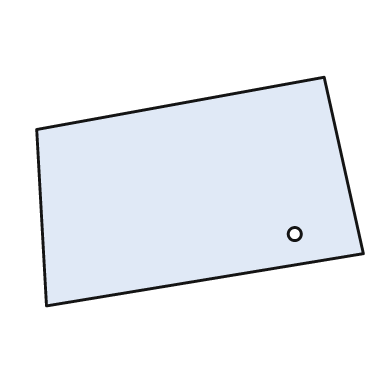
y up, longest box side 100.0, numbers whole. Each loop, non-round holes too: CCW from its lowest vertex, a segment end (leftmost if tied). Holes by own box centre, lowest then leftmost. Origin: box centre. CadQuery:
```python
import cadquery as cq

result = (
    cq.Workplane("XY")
    .moveTo(-47.0, -35.0)
    .lineTo(50.0, -19.0)
    .lineTo(38.0, 35.0)
    .lineTo(-50.0, 19.0)
    .close()
    .moveTo(29.0, -13.0)
    .circle(2.0)
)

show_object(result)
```